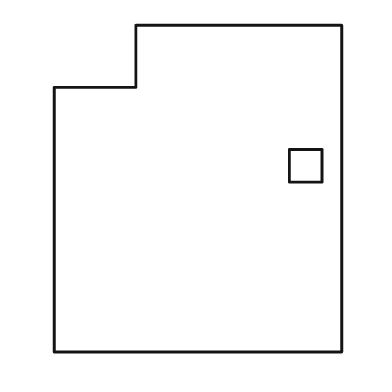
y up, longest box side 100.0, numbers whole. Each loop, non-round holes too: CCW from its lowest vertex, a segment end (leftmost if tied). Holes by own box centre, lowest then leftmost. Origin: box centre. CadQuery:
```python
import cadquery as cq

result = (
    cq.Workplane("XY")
    .moveTo(-44.0, -50.0)
    .lineTo(44.0, -50.0)
    .lineTo(44.0, 50.0)
    .lineTo(-19.0, 50.0)
    .lineTo(-19.0, 31.0)
    .lineTo(-44.0, 31.0)
    .close()
    .moveTo(28.0, 2.0)
    .lineTo(38.0, 2.0)
    .lineTo(38.0, 12.0)
    .lineTo(28.0, 12.0)
    .close()
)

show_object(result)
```